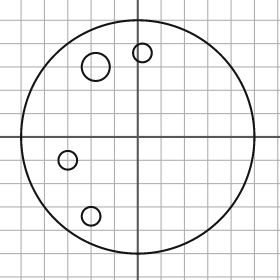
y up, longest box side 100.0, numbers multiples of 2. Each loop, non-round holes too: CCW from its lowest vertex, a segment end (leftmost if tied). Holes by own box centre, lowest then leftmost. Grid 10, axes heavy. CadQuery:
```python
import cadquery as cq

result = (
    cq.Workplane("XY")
    .moveTo(0.0, 0.0)
    .circle(50.0)
    .moveTo(-20.0, -34.0)
    .circle(4.0)
    .moveTo(-30.0, -10.0)
    .circle(4.0)
    .moveTo(-18.0, 30.0)
    .circle(6.0)
    .moveTo(2.0, 36.0)
    .circle(4.0)
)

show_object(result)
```